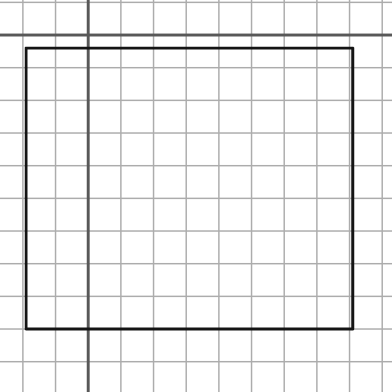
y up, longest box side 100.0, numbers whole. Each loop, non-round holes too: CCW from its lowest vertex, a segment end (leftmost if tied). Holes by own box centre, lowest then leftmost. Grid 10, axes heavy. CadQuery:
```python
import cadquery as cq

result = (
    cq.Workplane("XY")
    .moveTo(-19.0, -90.0)
    .lineTo(81.0, -90.0)
    .lineTo(81.0, -4.0)
    .lineTo(-19.0, -4.0)
    .close()
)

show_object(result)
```